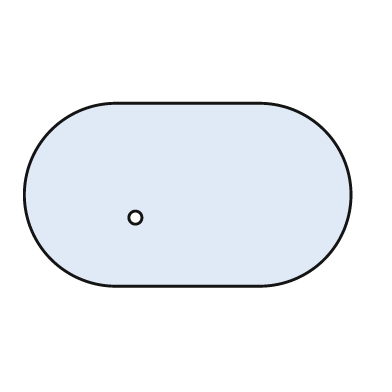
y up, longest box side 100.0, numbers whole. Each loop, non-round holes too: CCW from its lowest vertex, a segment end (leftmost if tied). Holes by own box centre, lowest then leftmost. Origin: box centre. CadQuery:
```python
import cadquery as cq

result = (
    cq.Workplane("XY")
    .moveTo(-22.0, -28.0)
    .lineTo(22.0, -28.0)
    .threePointArc((50.0, 0.0), (22.0, 28.0))
    .lineTo(-22.0, 28.0)
    .threePointArc((-50.0, 0.0), (-22.0, -28.0))
    .close()
    .moveTo(-16.0, -7.0)
    .circle(2.0)
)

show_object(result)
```